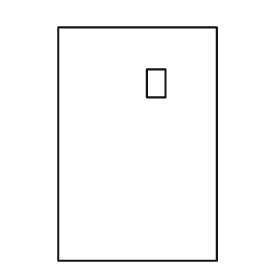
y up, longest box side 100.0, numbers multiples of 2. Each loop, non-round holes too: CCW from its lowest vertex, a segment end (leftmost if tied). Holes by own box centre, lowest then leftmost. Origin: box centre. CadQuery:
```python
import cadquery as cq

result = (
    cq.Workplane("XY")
    .moveTo(-34.0, -50.0)
    .lineTo(34.0, -50.0)
    .lineTo(34.0, 50.0)
    .lineTo(-34.0, 50.0)
    .close()
    .moveTo(4.0, 20.0)
    .lineTo(12.0, 20.0)
    .lineTo(12.0, 32.0)
    .lineTo(4.0, 32.0)
    .close()
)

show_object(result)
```